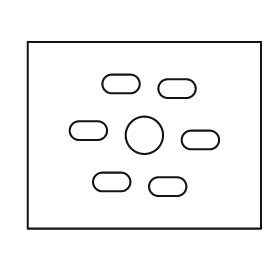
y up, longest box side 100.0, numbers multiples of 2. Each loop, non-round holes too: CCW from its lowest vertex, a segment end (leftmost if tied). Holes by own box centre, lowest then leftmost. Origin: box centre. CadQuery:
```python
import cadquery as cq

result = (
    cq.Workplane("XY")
    .moveTo(-50.0, -40.0)
    .lineTo(50.0, -40.0)
    .lineTo(50.0, 40.0)
    .lineTo(-50.0, 40.0)
    .close()
    .moveTo(6.0, -26.0)
    .lineTo(14.0, -26.0)
    .threePointArc((18.0, -22.0), (14.0, -18.0))
    .lineTo(6.0, -18.0)
    .threePointArc((2.0, -22.0), (6.0, -26.0))
    .close()
    .moveTo(-18.0, -24.0)
    .lineTo(-10.0, -24.0)
    .threePointArc((-6.0, -20.0), (-10.0, -16.0))
    .lineTo(-18.0, -16.0)
    .threePointArc((-22.0, -20.0), (-18.0, -24.0))
    .close()
    .moveTo(20.0, -6.0)
    .lineTo(28.0, -6.0)
    .threePointArc((32.0, -2.0), (28.0, 2.0))
    .lineTo(20.0, 2.0)
    .threePointArc((16.0, -2.0), (20.0, -6.0))
    .close()
    .moveTo(0.0, 0.0)
    .circle(8.0)
    .moveTo(-28.0, -2.0)
    .lineTo(-20.0, -2.0)
    .threePointArc((-16.0, 2.0), (-20.0, 6.0))
    .lineTo(-28.0, 6.0)
    .threePointArc((-32.0, 2.0), (-28.0, -2.0))
    .close()
    .moveTo(10.0, 16.0)
    .lineTo(18.0, 16.0)
    .threePointArc((22.0, 20.0), (18.0, 24.0))
    .lineTo(10.0, 24.0)
    .threePointArc((6.0, 20.0), (10.0, 16.0))
    .close()
    .moveTo(-14.0, 18.0)
    .lineTo(-6.0, 18.0)
    .threePointArc((-2.0, 22.0), (-6.0, 26.0))
    .lineTo(-14.0, 26.0)
    .threePointArc((-18.0, 22.0), (-14.0, 18.0))
    .close()
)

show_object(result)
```